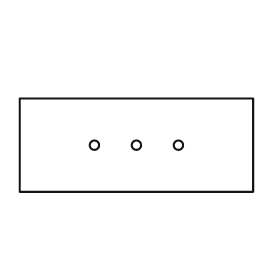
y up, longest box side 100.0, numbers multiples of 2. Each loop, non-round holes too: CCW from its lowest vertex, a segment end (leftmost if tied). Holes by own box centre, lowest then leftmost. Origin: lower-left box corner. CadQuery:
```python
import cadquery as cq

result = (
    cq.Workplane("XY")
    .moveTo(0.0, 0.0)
    .lineTo(100.0, 0.0)
    .lineTo(100.0, 40.0)
    .lineTo(0.0, 40.0)
    .close()
    .moveTo(32.0, 20.0)
    .circle(2.0)
    .moveTo(50.0, 20.0)
    .circle(2.0)
    .moveTo(68.0, 20.0)
    .circle(2.0)
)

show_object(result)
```